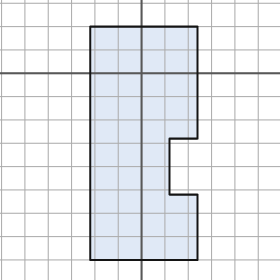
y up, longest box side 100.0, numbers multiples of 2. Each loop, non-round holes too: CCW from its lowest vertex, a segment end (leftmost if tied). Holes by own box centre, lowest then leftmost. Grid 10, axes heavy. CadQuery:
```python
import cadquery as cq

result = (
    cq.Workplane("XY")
    .moveTo(-22.0, -80.0)
    .lineTo(24.0, -80.0)
    .lineTo(24.0, -52.0)
    .lineTo(12.0, -52.0)
    .lineTo(12.0, -28.0)
    .lineTo(24.0, -28.0)
    .lineTo(24.0, 20.0)
    .lineTo(-22.0, 20.0)
    .close()
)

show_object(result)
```